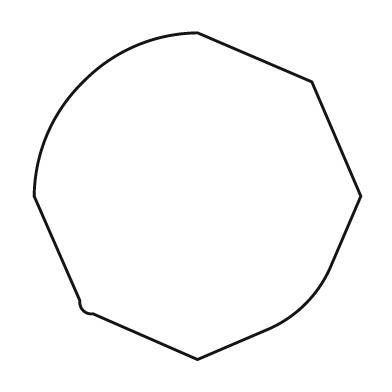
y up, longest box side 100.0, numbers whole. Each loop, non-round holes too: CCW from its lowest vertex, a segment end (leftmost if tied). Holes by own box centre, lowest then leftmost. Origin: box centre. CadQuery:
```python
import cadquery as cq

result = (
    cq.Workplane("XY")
    .moveTo(0.0, -50.0)
    .lineTo(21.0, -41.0)
    .threePointArc((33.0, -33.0), (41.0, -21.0))
    .lineTo(50.0, 0.0)
    .lineTo(35.0, 35.0)
    .lineTo(0.0, 50.0)
    .threePointArc((-19.0, 46.0), (-35.0, 35.0))
    .threePointArc((-46.0, 19.0), (-50.0, 0.0))
    .lineTo(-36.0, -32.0)
    .threePointArc((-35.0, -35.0), (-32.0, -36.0))
    .close()
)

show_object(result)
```